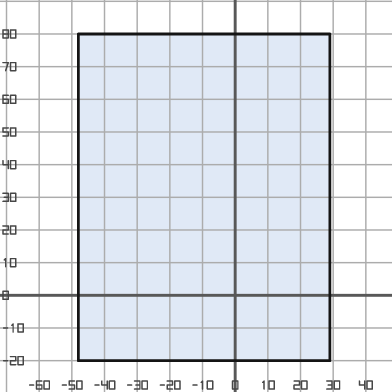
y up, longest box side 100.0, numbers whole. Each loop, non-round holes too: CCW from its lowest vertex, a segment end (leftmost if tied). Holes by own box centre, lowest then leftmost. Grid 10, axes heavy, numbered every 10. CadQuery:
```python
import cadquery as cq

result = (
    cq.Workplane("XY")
    .moveTo(-48.0, -20.0)
    .lineTo(29.0, -20.0)
    .lineTo(29.0, 80.0)
    .lineTo(-48.0, 80.0)
    .close()
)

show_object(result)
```